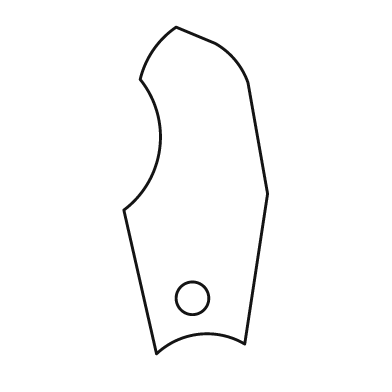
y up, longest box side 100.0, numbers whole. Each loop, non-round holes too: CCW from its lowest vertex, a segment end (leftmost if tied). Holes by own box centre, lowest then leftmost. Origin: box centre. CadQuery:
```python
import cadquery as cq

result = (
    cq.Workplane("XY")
    .moveTo(-12.0, -50.0)
    .threePointArc((1.0, -44.0), (15.0, -47.0))
    .lineTo(22.0, -1.0)
    .lineTo(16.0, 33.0)
    .threePointArc((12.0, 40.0), (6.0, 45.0))
    .lineTo(-6.0, 50.0)
    .threePointArc((-13.0, 43.0), (-17.0, 34.0))
    .threePointArc((-11.0, 13.0), (-22.0, -6.0))
    .close()
    .moveTo(-1.0, -33.0)
    .circle(5.0)
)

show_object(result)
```